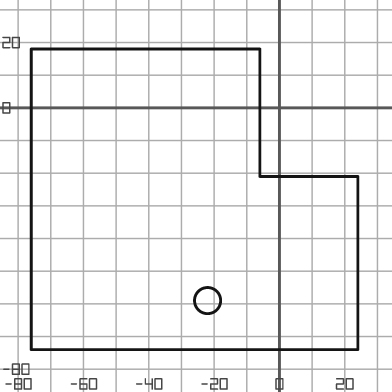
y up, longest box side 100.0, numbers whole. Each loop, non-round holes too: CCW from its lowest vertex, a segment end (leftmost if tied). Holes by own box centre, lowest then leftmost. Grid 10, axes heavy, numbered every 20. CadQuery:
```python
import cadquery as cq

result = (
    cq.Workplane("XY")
    .moveTo(-76.0, -74.0)
    .lineTo(24.0, -74.0)
    .lineTo(24.0, -21.0)
    .lineTo(-6.0, -21.0)
    .lineTo(-6.0, 18.0)
    .lineTo(-76.0, 18.0)
    .close()
    .moveTo(-22.0, -59.0)
    .circle(4.0)
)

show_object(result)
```